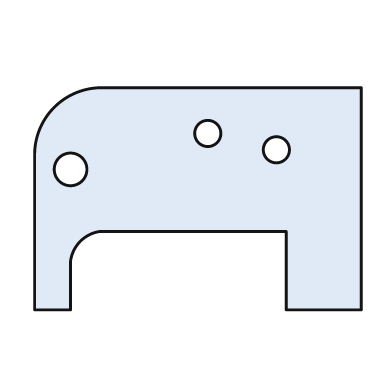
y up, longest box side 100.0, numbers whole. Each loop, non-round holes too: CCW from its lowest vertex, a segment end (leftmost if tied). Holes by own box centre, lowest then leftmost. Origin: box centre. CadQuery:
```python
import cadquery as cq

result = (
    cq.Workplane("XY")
    .moveTo(-50.0, -34.0)
    .lineTo(-39.0, -34.0)
    .lineTo(-39.0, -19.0)
    .threePointArc((-36.0, -13.0), (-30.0, -10.0))
    .lineTo(27.0, -10.0)
    .lineTo(27.0, -34.0)
    .lineTo(50.0, -34.0)
    .lineTo(50.0, 34.0)
    .lineTo(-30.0, 34.0)
    .threePointArc((-44.0, 28.0), (-50.0, 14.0))
    .close()
    .moveTo(-39.0, 9.0)
    .circle(5.0)
    .moveTo(24.0, 15.0)
    .circle(4.0)
    .moveTo(3.0, 20.0)
    .circle(4.0)
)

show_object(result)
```